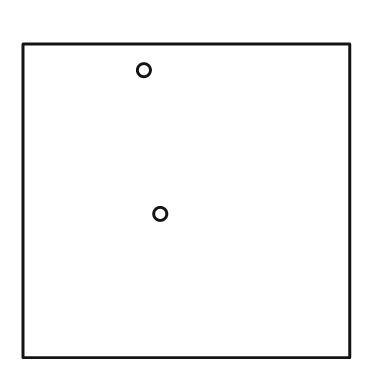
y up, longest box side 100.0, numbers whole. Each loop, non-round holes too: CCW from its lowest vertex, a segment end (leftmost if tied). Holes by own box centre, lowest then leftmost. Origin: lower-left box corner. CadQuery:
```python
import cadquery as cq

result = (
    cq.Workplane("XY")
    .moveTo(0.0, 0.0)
    .lineTo(100.0, 0.0)
    .lineTo(100.0, 96.0)
    .lineTo(0.0, 96.0)
    .close()
    .moveTo(42.0, 44.0)
    .circle(2.0)
    .moveTo(37.0, 88.0)
    .circle(2.0)
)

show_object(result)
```